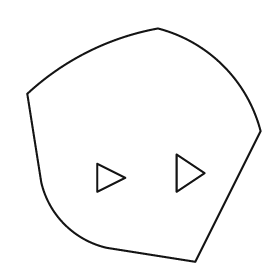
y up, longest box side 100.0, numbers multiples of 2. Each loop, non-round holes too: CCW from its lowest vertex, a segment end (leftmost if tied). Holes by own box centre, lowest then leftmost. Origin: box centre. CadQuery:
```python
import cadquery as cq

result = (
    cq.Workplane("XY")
    .moveTo(22.0, -50.0)
    .lineTo(50.0, 6.0)
    .threePointArc((34.0, 34.0), (6.0, 50.0))
    .threePointArc((-24.0, 40.0), (-50.0, 22.0))
    .lineTo(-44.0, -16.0)
    .threePointArc((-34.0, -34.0), (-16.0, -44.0))
    .close()
    .moveTo(-20.0, -20.0)
    .lineTo(-8.0, -14.0)
    .lineTo(-20.0, -8.0)
    .close()
    .moveTo(14.0, -20.0)
    .lineTo(26.0, -12.0)
    .lineTo(14.0, -4.0)
    .close()
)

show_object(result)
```